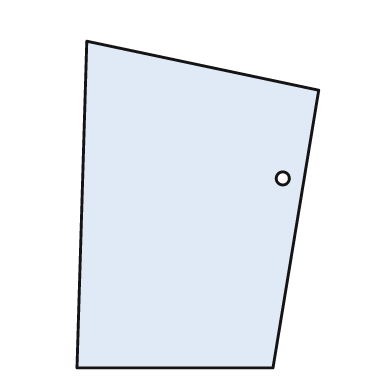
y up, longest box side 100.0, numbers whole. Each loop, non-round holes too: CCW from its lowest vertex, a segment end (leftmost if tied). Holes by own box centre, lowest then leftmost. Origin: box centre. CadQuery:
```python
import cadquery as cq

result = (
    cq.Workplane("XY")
    .moveTo(-37.0, -50.0)
    .lineTo(23.0, -50.0)
    .lineTo(37.0, 35.0)
    .lineTo(-34.0, 50.0)
    .close()
    .moveTo(26.0, 8.0)
    .circle(2.0)
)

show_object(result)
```